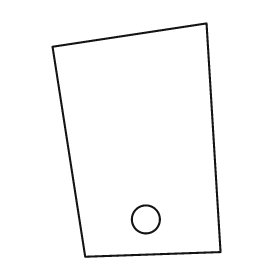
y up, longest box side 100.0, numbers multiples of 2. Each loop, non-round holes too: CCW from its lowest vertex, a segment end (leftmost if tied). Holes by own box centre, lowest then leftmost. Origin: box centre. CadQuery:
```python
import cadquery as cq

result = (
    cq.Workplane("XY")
    .moveTo(-22.0, -50.0)
    .lineTo(36.0, -48.0)
    .lineTo(30.0, 50.0)
    .lineTo(-36.0, 40.0)
    .close()
    .moveTo(4.0, -34.0)
    .circle(6.0)
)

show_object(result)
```